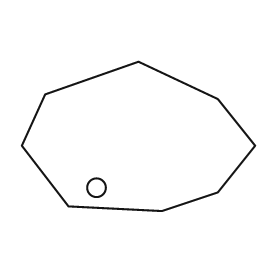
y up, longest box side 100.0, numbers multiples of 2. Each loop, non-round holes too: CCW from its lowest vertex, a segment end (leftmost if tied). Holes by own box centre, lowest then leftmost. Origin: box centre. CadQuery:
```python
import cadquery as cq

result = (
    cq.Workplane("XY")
    .moveTo(10.0, -32.0)
    .lineTo(34.0, -24.0)
    .lineTo(50.0, -4.0)
    .lineTo(34.0, 16.0)
    .lineTo(0.0, 32.0)
    .lineTo(-40.0, 18.0)
    .lineTo(-50.0, -4.0)
    .lineTo(-30.0, -30.0)
    .close()
    .moveTo(-18.0, -22.0)
    .circle(4.0)
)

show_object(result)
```